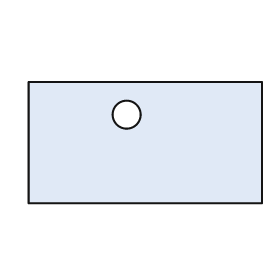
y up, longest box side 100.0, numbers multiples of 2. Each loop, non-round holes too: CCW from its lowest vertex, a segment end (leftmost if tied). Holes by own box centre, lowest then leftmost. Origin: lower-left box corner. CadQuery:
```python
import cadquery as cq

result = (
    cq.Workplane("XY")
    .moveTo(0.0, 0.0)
    .lineTo(100.0, 0.0)
    .lineTo(100.0, 52.0)
    .lineTo(0.0, 52.0)
    .close()
    .moveTo(42.0, 38.0)
    .circle(6.0)
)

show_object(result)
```